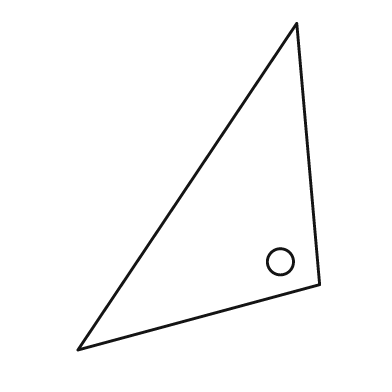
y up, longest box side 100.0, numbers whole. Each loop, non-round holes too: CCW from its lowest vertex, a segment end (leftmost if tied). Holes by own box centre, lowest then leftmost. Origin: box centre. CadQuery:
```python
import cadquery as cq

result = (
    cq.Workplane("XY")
    .moveTo(-37.0, -50.0)
    .lineTo(37.0, -30.0)
    .lineTo(30.0, 50.0)
    .close()
    .moveTo(25.0, -23.0)
    .circle(4.0)
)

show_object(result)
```